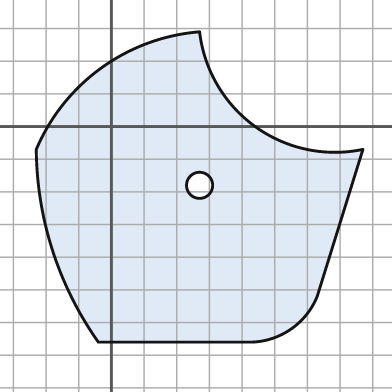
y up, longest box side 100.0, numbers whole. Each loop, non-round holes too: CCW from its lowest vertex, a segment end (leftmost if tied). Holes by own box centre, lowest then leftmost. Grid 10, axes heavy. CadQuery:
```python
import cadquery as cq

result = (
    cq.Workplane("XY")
    .moveTo(-4.0, -66.0)
    .lineTo(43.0, -66.0)
    .threePointArc((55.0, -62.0), (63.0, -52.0))
    .lineTo(77.0, -7.0)
    .threePointArc((44.0, 0.0), (27.0, 29.0))
    .threePointArc((-3.0, 18.0), (-23.0, -7.0))
    .threePointArc((-18.0, -38.0), (-4.0, -66.0))
    .close()
    .moveTo(27.0, -18.0)
    .circle(4.0)
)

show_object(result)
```